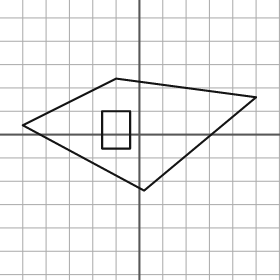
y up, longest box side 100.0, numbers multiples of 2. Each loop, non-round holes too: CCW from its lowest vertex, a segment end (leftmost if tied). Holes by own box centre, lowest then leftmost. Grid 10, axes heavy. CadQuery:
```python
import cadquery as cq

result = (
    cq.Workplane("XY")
    .moveTo(2.0, -24.0)
    .lineTo(50.0, 16.0)
    .lineTo(-10.0, 24.0)
    .lineTo(-50.0, 4.0)
    .close()
    .moveTo(-16.0, -6.0)
    .lineTo(-4.0, -6.0)
    .lineTo(-4.0, 10.0)
    .lineTo(-16.0, 10.0)
    .close()
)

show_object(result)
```